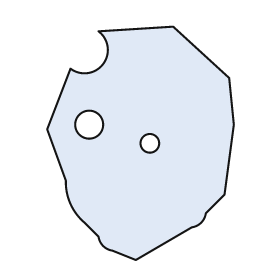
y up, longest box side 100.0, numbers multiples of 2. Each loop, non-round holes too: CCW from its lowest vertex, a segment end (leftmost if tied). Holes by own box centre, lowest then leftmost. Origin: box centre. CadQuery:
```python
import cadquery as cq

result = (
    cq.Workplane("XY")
    .moveTo(-2.0, -50.0)
    .lineTo(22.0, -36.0)
    .threePointArc((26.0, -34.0), (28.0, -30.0))
    .lineTo(36.0, -22.0)
    .lineTo(40.0, 8.0)
    .lineTo(38.0, 28.0)
    .lineTo(14.0, 50.0)
    .lineTo(-18.0, 48.0)
    .threePointArc((-16.0, 34.0), (-30.0, 32.0))
    .lineTo(-40.0, 6.0)
    .lineTo(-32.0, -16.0)
    .threePointArc((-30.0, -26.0), (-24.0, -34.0))
    .lineTo(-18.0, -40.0)
    .threePointArc((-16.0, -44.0), (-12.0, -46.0))
    .close()
    .moveTo(4.0, 0.0)
    .circle(4.0)
    .moveTo(-22.0, 8.0)
    .circle(6.0)
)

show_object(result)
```